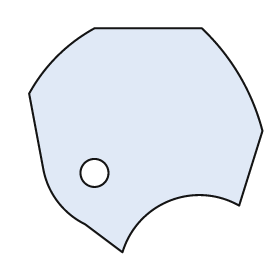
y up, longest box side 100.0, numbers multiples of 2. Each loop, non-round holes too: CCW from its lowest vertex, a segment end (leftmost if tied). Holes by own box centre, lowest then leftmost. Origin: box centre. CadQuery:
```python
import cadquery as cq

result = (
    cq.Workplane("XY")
    .moveTo(-10.0, -48.0)
    .threePointArc((10.0, -26.0), (40.0, -28.0))
    .lineTo(50.0, 4.0)
    .threePointArc((40.0, 28.0), (24.0, 48.0))
    .lineTo(-22.0, 48.0)
    .threePointArc((-38.0, 36.0), (-50.0, 20.0))
    .lineTo(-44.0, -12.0)
    .threePointArc((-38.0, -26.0), (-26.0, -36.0))
    .close()
    .moveTo(-22.0, -14.0)
    .circle(6.0)
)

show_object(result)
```